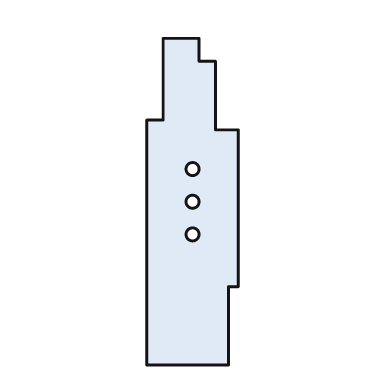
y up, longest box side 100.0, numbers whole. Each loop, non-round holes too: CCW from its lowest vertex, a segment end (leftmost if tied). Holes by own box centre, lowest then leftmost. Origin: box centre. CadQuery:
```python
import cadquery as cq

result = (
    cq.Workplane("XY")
    .moveTo(-14.0, -50.0)
    .lineTo(11.0, -50.0)
    .lineTo(11.0, -26.0)
    .lineTo(14.0, -26.0)
    .lineTo(14.0, 22.0)
    .lineTo(7.0, 22.0)
    .lineTo(7.0, 43.0)
    .lineTo(2.0, 43.0)
    .lineTo(2.0, 50.0)
    .lineTo(-9.0, 50.0)
    .lineTo(-9.0, 25.0)
    .lineTo(-14.0, 25.0)
    .close()
    .moveTo(0.0, -10.0)
    .circle(2.0)
    .moveTo(0.0, 0.0)
    .circle(2.0)
    .moveTo(0.0, 10.0)
    .circle(2.0)
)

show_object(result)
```